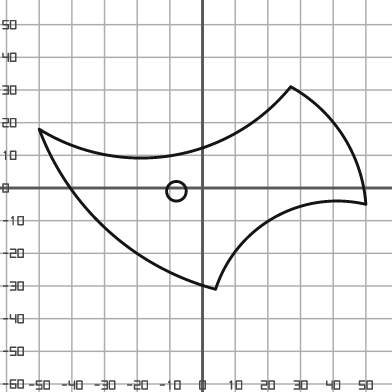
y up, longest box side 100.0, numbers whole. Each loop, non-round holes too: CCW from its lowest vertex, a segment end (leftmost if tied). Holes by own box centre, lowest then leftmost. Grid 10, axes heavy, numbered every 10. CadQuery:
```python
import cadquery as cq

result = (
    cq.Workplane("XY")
    .moveTo(4.0, -31.0)
    .threePointArc((22.0, -9.0), (50.0, -5.0))
    .threePointArc((43.0, 16.0), (27.0, 31.0))
    .threePointArc((-9.0, 10.0), (-50.0, 18.0))
    .threePointArc((-29.0, -13.0), (4.0, -31.0))
    .close()
    .moveTo(-8.0, -1.0)
    .circle(3.0)
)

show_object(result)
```